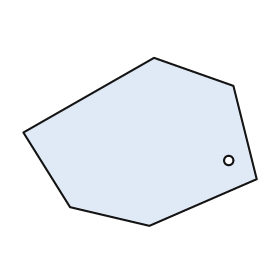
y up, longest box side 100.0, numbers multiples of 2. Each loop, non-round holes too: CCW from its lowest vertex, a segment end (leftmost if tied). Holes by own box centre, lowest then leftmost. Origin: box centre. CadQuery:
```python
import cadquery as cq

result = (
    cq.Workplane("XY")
    .moveTo(4.0, -36.0)
    .lineTo(50.0, -16.0)
    .lineTo(40.0, 24.0)
    .lineTo(6.0, 36.0)
    .lineTo(-50.0, 4.0)
    .lineTo(-30.0, -28.0)
    .close()
    .moveTo(38.0, -8.0)
    .circle(2.0)
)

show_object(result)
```